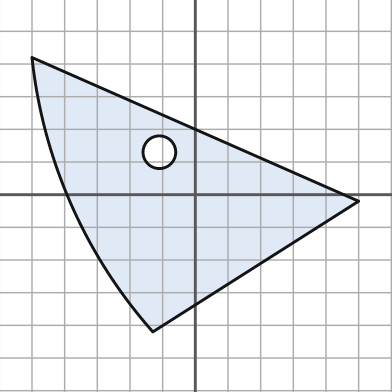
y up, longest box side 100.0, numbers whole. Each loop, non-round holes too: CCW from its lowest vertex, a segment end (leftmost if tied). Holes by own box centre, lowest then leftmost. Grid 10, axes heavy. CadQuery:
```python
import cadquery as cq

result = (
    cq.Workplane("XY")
    .moveTo(-13.0, -42.0)
    .lineTo(50.0, -2.0)
    .lineTo(-50.0, 42.0)
    .threePointArc((-38.0, -3.0), (-13.0, -42.0))
    .close()
    .moveTo(-11.0, 13.0)
    .circle(5.0)
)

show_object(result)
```